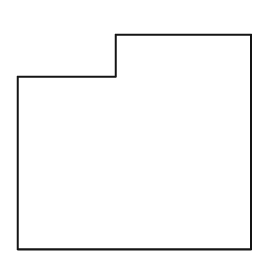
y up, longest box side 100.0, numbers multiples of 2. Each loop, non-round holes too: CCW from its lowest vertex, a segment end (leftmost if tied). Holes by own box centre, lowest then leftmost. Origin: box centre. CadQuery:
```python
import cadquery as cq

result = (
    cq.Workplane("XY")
    .moveTo(-50.0, -46.0)
    .lineTo(50.0, -46.0)
    .lineTo(50.0, 46.0)
    .lineTo(-8.0, 46.0)
    .lineTo(-8.0, 28.0)
    .lineTo(-50.0, 28.0)
    .close()
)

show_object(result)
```